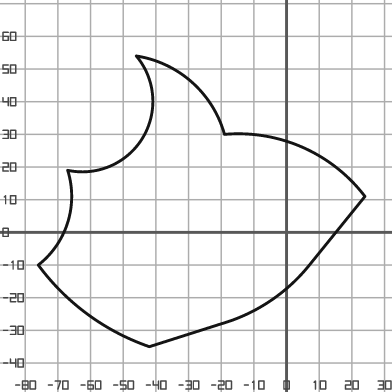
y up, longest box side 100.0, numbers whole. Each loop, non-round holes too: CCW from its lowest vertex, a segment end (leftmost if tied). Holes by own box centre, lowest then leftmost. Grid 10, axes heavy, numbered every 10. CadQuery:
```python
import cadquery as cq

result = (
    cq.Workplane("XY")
    .moveTo(-42.0, -35.0)
    .lineTo(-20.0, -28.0)
    .threePointArc((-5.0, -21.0), (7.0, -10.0))
    .lineTo(24.0, 11.0)
    .threePointArc((5.0, 26.0), (-19.0, 30.0))
    .threePointArc((-29.0, 46.0), (-46.0, 54.0))
    .threePointArc((-44.0, 29.0), (-67.0, 19.0))
    .threePointArc((-67.0, 3.0), (-76.0, -10.0))
    .threePointArc((-61.0, -25.0), (-42.0, -35.0))
    .close()
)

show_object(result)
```